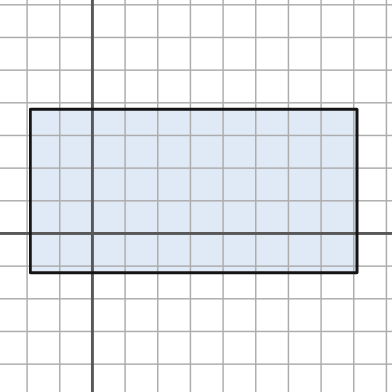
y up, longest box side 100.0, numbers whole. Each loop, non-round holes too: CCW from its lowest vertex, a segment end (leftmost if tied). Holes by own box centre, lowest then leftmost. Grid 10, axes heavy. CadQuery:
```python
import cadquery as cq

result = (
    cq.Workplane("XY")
    .moveTo(-19.0, -12.0)
    .lineTo(81.0, -12.0)
    .lineTo(81.0, 38.0)
    .lineTo(-19.0, 38.0)
    .close()
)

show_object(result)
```